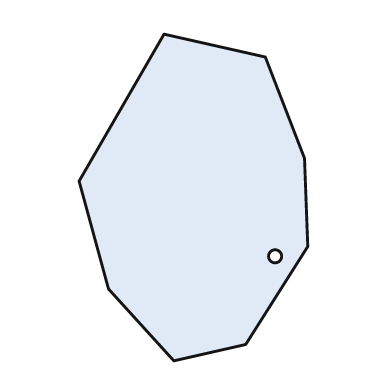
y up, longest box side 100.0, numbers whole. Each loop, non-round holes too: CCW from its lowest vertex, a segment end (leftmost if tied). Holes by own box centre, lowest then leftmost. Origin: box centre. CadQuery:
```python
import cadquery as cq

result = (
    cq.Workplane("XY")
    .moveTo(-6.0, -50.0)
    .lineTo(16.0, -45.0)
    .lineTo(35.0, -15.0)
    .lineTo(34.0, 12.0)
    .lineTo(22.0, 43.0)
    .lineTo(-9.0, 50.0)
    .lineTo(-35.0, 5.0)
    .lineTo(-26.0, -28.0)
    .close()
    .moveTo(25.0, -18.0)
    .circle(2.0)
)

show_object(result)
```